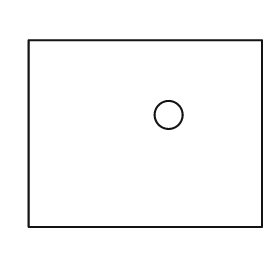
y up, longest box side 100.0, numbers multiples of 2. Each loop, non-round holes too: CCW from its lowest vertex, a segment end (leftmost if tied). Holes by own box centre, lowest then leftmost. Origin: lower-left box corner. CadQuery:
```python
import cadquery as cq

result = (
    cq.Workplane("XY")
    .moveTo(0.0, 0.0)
    .lineTo(100.0, 0.0)
    .lineTo(100.0, 80.0)
    .lineTo(0.0, 80.0)
    .close()
    .moveTo(60.0, 48.0)
    .circle(6.0)
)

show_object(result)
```